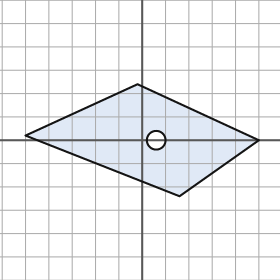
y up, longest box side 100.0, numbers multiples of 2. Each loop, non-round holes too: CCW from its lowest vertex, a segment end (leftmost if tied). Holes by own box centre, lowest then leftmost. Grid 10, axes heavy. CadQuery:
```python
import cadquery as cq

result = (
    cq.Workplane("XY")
    .moveTo(16.0, -24.0)
    .lineTo(50.0, 0.0)
    .lineTo(-2.0, 24.0)
    .lineTo(-50.0, 2.0)
    .close()
    .moveTo(6.0, 0.0)
    .circle(4.0)
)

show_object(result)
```